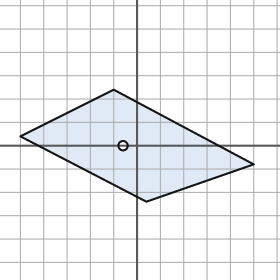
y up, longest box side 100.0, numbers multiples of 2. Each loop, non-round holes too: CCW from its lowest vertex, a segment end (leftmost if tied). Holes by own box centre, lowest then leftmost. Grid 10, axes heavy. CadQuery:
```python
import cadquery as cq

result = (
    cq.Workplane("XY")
    .moveTo(4.0, -24.0)
    .lineTo(50.0, -8.0)
    .lineTo(-10.0, 24.0)
    .lineTo(-50.0, 4.0)
    .close()
    .moveTo(-6.0, 0.0)
    .circle(2.0)
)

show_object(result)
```